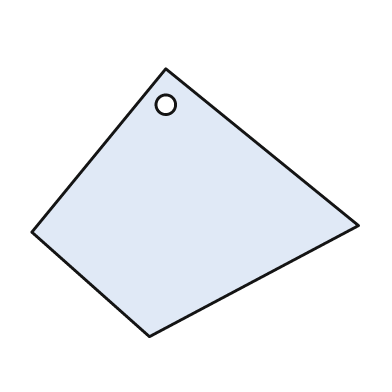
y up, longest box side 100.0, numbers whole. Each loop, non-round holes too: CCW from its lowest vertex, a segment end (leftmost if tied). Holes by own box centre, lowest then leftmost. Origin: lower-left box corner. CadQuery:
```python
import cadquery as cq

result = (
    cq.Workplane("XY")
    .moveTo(36.0, 0.0)
    .lineTo(100.0, 34.0)
    .lineTo(41.0, 82.0)
    .lineTo(0.0, 32.0)
    .close()
    .moveTo(41.0, 71.0)
    .circle(3.0)
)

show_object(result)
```